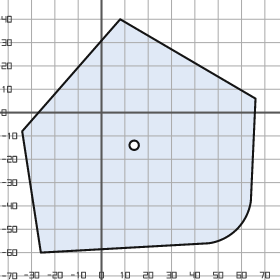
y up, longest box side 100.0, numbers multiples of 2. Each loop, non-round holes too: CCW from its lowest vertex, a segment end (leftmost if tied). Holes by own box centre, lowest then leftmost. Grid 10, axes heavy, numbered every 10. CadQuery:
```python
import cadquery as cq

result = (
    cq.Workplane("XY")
    .moveTo(-26.0, -60.0)
    .lineTo(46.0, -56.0)
    .threePointArc((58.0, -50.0), (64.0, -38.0))
    .lineTo(66.0, 6.0)
    .lineTo(8.0, 40.0)
    .lineTo(-34.0, -8.0)
    .close()
    .moveTo(14.0, -14.0)
    .circle(2.0)
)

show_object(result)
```